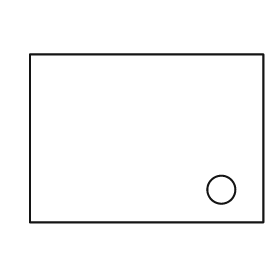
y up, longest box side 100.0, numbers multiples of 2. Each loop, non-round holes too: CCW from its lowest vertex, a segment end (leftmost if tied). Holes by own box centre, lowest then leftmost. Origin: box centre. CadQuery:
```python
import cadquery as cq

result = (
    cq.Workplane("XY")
    .moveTo(-50.0, -36.0)
    .lineTo(50.0, -36.0)
    .lineTo(50.0, 36.0)
    .lineTo(-50.0, 36.0)
    .close()
    .moveTo(32.0, -22.0)
    .circle(6.0)
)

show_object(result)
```